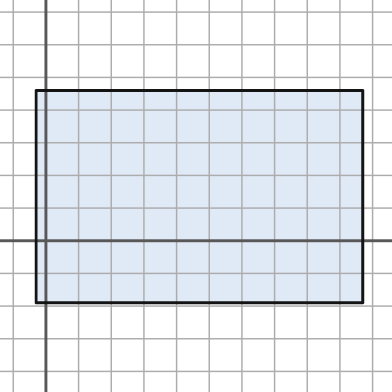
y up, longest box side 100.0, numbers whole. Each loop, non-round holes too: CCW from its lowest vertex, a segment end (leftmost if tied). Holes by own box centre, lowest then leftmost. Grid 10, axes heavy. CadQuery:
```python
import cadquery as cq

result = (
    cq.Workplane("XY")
    .moveTo(-3.0, -19.0)
    .lineTo(97.0, -19.0)
    .lineTo(97.0, 46.0)
    .lineTo(-3.0, 46.0)
    .close()
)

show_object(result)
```